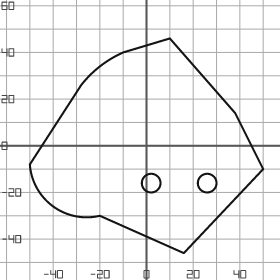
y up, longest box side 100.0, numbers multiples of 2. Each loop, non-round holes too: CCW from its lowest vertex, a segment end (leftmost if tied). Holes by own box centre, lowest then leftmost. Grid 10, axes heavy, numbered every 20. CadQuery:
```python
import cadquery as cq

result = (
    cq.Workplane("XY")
    .moveTo(16.0, -46.0)
    .lineTo(50.0, -10.0)
    .lineTo(38.0, 14.0)
    .lineTo(10.0, 46.0)
    .lineTo(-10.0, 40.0)
    .threePointArc((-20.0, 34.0), (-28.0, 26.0))
    .lineTo(-50.0, -8.0)
    .threePointArc((-40.0, -26.0), (-20.0, -30.0))
    .close()
    .moveTo(2.0, -16.0)
    .circle(4.0)
    .moveTo(26.0, -16.0)
    .circle(4.0)
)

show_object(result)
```